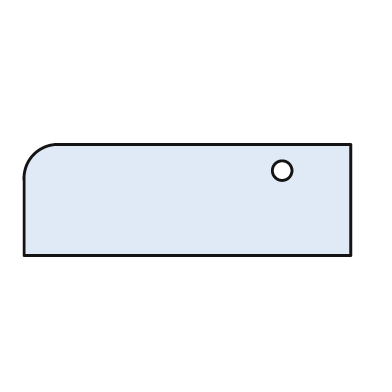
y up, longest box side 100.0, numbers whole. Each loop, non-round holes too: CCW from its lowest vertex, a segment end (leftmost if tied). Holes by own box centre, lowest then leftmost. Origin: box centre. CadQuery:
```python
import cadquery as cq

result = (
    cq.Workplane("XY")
    .moveTo(-50.0, -17.0)
    .lineTo(50.0, -17.0)
    .lineTo(50.0, 17.0)
    .lineTo(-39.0, 17.0)
    .threePointArc((-47.0, 14.0), (-50.0, 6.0))
    .close()
    .moveTo(29.0, 9.0)
    .circle(3.0)
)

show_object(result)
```